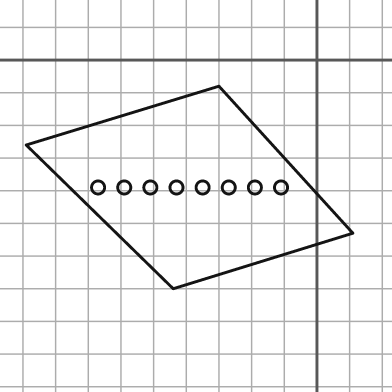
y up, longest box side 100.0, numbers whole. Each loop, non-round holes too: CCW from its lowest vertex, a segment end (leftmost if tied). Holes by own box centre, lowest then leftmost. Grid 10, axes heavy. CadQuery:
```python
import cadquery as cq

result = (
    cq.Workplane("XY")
    .moveTo(-44.0, -70.0)
    .lineTo(11.0, -53.0)
    .lineTo(-30.0, -8.0)
    .lineTo(-89.0, -26.0)
    .close()
    .moveTo(-67.0, -39.0)
    .circle(2.0)
    .moveTo(-59.0, -39.0)
    .circle(2.0)
    .moveTo(-51.0, -39.0)
    .circle(2.0)
    .moveTo(-43.0, -39.0)
    .circle(2.0)
    .moveTo(-35.0, -39.0)
    .circle(2.0)
    .moveTo(-27.0, -39.0)
    .circle(2.0)
    .moveTo(-19.0, -39.0)
    .circle(2.0)
    .moveTo(-11.0, -39.0)
    .circle(2.0)
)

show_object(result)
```